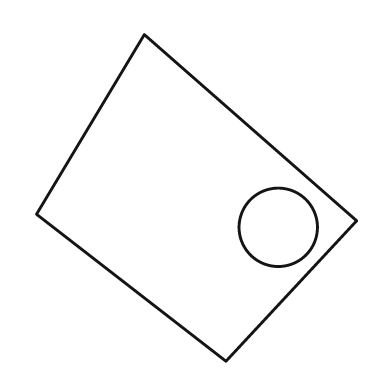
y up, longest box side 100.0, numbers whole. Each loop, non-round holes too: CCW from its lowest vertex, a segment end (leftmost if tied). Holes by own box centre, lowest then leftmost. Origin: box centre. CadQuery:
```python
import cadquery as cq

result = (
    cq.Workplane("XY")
    .moveTo(9.0, -50.0)
    .lineTo(49.0, -7.0)
    .lineTo(-16.0, 50.0)
    .lineTo(-49.0, -5.0)
    .close()
    .moveTo(25.0, -9.0)
    .circle(12.0)
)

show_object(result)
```